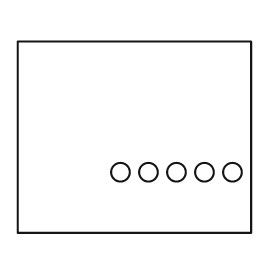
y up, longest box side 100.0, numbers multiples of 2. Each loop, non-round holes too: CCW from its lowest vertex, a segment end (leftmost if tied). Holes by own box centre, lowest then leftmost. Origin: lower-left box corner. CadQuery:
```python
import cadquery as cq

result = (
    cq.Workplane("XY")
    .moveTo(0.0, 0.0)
    .lineTo(100.0, 0.0)
    .lineTo(100.0, 82.0)
    .lineTo(0.0, 82.0)
    .close()
    .moveTo(44.0, 26.0)
    .circle(4.0)
    .moveTo(56.0, 26.0)
    .circle(4.0)
    .moveTo(68.0, 26.0)
    .circle(4.0)
    .moveTo(80.0, 26.0)
    .circle(4.0)
    .moveTo(92.0, 26.0)
    .circle(4.0)
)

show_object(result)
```